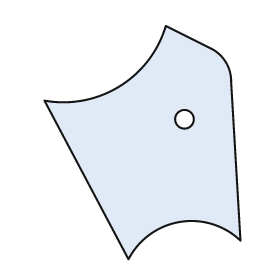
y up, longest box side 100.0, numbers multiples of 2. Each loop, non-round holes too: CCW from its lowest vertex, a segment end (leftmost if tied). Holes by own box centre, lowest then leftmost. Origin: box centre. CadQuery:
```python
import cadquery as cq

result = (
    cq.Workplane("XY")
    .moveTo(-6.0, -50.0)
    .threePointArc((16.0, -34.0), (42.0, -42.0))
    .lineTo(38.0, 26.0)
    .threePointArc((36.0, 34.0), (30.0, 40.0))
    .lineTo(10.0, 50.0)
    .threePointArc((-10.0, 24.0), (-42.0, 18.0))
    .close()
    .moveTo(18.0, 10.0)
    .circle(4.0)
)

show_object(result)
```